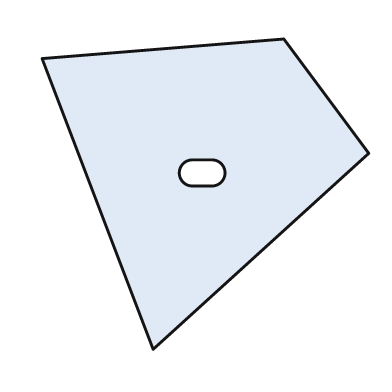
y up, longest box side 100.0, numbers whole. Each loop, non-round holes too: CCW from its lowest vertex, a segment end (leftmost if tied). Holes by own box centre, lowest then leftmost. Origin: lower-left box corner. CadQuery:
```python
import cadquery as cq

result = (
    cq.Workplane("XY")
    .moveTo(34.0, 0.0)
    .lineTo(100.0, 60.0)
    .lineTo(74.0, 95.0)
    .lineTo(0.0, 89.0)
    .close()
    .moveTo(46.0, 50.0)
    .lineTo(52.0, 50.0)
    .threePointArc((56.0, 54.0), (52.0, 58.0))
    .lineTo(46.0, 58.0)
    .threePointArc((42.0, 54.0), (46.0, 50.0))
    .close()
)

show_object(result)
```